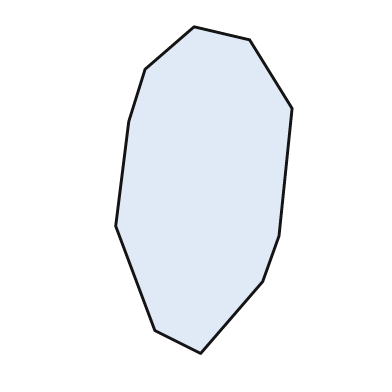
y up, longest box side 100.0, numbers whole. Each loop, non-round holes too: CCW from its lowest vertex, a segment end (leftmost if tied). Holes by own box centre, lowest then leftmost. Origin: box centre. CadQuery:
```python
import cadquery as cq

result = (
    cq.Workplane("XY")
    .moveTo(-1.0, -50.0)
    .lineTo(18.0, -28.0)
    .lineTo(23.0, -14.0)
    .lineTo(27.0, 25.0)
    .lineTo(14.0, 46.0)
    .lineTo(-3.0, 50.0)
    .lineTo(-18.0, 37.0)
    .lineTo(-23.0, 21.0)
    .lineTo(-27.0, -11.0)
    .lineTo(-15.0, -43.0)
    .close()
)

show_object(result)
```